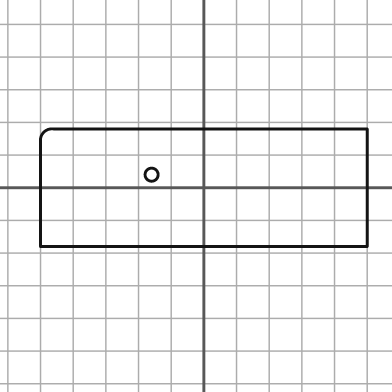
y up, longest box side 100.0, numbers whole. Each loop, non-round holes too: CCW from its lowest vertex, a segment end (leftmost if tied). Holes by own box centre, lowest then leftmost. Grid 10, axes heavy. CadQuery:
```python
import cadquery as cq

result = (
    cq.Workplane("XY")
    .moveTo(-50.0, -18.0)
    .lineTo(50.0, -18.0)
    .lineTo(50.0, 18.0)
    .lineTo(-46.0, 18.0)
    .threePointArc((-49.0, 17.0), (-50.0, 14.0))
    .close()
    .moveTo(-16.0, 4.0)
    .circle(2.0)
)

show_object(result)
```